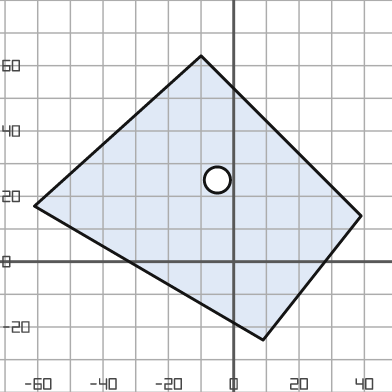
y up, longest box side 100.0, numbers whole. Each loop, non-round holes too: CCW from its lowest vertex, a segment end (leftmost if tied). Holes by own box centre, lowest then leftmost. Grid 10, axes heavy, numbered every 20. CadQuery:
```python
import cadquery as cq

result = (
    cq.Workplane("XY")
    .moveTo(9.0, -24.0)
    .lineTo(39.0, 14.0)
    .lineTo(-10.0, 63.0)
    .lineTo(-61.0, 17.0)
    .close()
    .moveTo(-5.0, 25.0)
    .circle(4.0)
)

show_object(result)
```